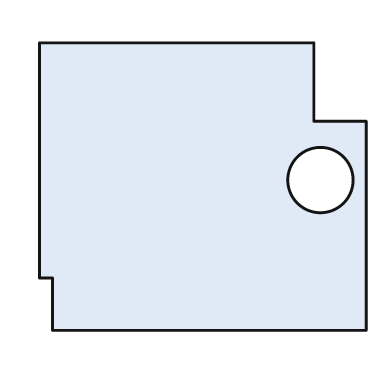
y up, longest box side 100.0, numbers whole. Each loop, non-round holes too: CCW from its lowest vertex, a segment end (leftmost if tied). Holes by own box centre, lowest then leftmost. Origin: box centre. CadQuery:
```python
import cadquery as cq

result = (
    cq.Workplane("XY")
    .moveTo(-46.0, -44.0)
    .lineTo(50.0, -44.0)
    .lineTo(50.0, 20.0)
    .lineTo(34.0, 20.0)
    .lineTo(34.0, 44.0)
    .lineTo(-50.0, 44.0)
    .lineTo(-50.0, -28.0)
    .lineTo(-46.0, -28.0)
    .close()
    .moveTo(36.0, 2.0)
    .circle(10.0)
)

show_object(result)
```